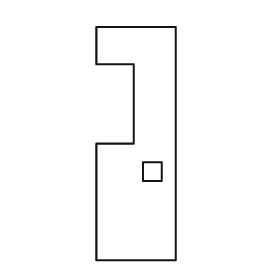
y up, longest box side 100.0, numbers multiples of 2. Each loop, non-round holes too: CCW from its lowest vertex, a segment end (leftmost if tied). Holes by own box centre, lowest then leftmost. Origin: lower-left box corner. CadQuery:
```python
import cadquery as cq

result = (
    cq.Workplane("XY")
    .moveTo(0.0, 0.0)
    .lineTo(34.0, 0.0)
    .lineTo(34.0, 100.0)
    .lineTo(0.0, 100.0)
    .lineTo(0.0, 84.0)
    .lineTo(16.0, 84.0)
    .lineTo(16.0, 50.0)
    .lineTo(0.0, 50.0)
    .close()
    .moveTo(20.0, 34.0)
    .lineTo(28.0, 34.0)
    .lineTo(28.0, 42.0)
    .lineTo(20.0, 42.0)
    .close()
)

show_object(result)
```